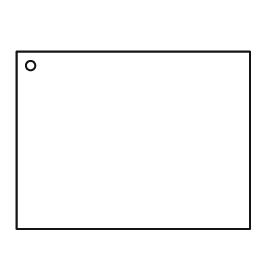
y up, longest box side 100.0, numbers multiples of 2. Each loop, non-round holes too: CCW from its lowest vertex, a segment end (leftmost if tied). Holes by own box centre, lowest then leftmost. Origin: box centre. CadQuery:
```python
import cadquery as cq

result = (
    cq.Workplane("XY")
    .moveTo(-50.0, -38.0)
    .lineTo(50.0, -38.0)
    .lineTo(50.0, 38.0)
    .lineTo(-50.0, 38.0)
    .close()
    .moveTo(-44.0, 32.0)
    .circle(2.0)
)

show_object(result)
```